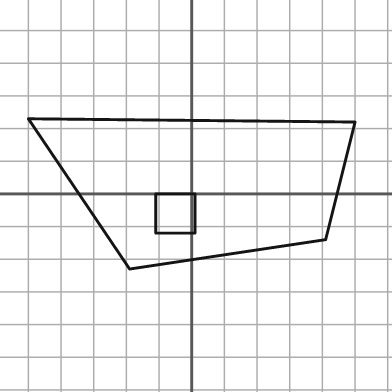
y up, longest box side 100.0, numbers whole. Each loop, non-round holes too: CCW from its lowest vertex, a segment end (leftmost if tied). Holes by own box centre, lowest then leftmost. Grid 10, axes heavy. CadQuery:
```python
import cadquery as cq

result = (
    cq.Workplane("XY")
    .moveTo(-19.0, -23.0)
    .lineTo(41.0, -14.0)
    .lineTo(50.0, 22.0)
    .lineTo(-50.0, 23.0)
    .close()
    .moveTo(-11.0, -12.0)
    .lineTo(1.0, -12.0)
    .lineTo(1.0, 0.0)
    .lineTo(-11.0, 0.0)
    .close()
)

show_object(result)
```